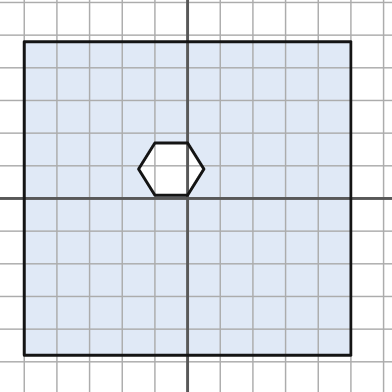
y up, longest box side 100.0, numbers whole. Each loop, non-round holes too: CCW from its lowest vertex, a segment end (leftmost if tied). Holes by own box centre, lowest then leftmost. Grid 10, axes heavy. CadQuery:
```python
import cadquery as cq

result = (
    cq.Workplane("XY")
    .moveTo(-50.0, -48.0)
    .lineTo(50.0, -48.0)
    .lineTo(50.0, 48.0)
    .lineTo(-50.0, 48.0)
    .close()
    .moveTo(-10.0, 1.0)
    .lineTo(0.0, 1.0)
    .lineTo(5.0, 9.0)
    .lineTo(0.0, 17.0)
    .lineTo(-10.0, 17.0)
    .lineTo(-15.0, 9.0)
    .close()
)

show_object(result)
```